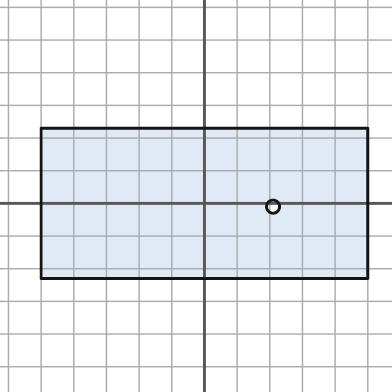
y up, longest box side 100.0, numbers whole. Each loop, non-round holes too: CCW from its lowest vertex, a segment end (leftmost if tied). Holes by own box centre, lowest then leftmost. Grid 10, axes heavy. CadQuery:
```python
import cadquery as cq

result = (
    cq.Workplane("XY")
    .moveTo(-50.0, -23.0)
    .lineTo(50.0, -23.0)
    .lineTo(50.0, 23.0)
    .lineTo(-50.0, 23.0)
    .close()
    .moveTo(21.0, -1.0)
    .circle(2.0)
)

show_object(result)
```